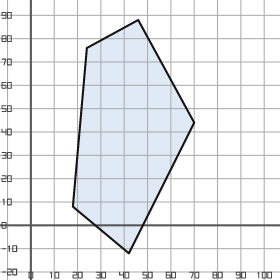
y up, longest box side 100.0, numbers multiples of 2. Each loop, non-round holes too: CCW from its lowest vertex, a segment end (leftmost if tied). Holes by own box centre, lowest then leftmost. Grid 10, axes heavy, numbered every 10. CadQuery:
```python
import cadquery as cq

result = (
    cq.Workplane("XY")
    .moveTo(42.0, -12.0)
    .lineTo(70.0, 44.0)
    .lineTo(46.0, 88.0)
    .lineTo(24.0, 76.0)
    .lineTo(18.0, 8.0)
    .close()
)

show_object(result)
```